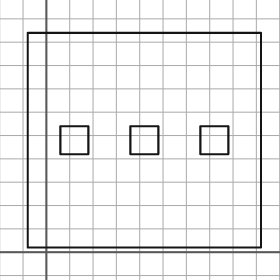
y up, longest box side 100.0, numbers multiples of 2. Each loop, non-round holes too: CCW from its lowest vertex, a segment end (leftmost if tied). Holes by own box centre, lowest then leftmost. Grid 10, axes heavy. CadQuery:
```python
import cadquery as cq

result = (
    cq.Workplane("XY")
    .moveTo(-8.0, 2.0)
    .lineTo(92.0, 2.0)
    .lineTo(92.0, 94.0)
    .lineTo(-8.0, 94.0)
    .close()
    .moveTo(6.0, 42.0)
    .lineTo(18.0, 42.0)
    .lineTo(18.0, 54.0)
    .lineTo(6.0, 54.0)
    .close()
    .moveTo(36.0, 42.0)
    .lineTo(48.0, 42.0)
    .lineTo(48.0, 54.0)
    .lineTo(36.0, 54.0)
    .close()
    .moveTo(66.0, 42.0)
    .lineTo(78.0, 42.0)
    .lineTo(78.0, 54.0)
    .lineTo(66.0, 54.0)
    .close()
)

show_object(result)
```